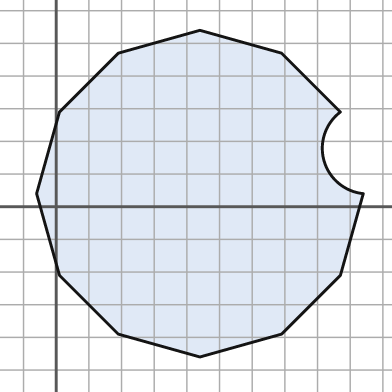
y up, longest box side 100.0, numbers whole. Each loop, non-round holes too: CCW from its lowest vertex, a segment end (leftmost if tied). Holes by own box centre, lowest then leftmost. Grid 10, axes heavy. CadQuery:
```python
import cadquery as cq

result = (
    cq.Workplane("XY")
    .moveTo(44.0, -46.0)
    .lineTo(69.0, -39.0)
    .lineTo(87.0, -21.0)
    .lineTo(94.0, 4.0)
    .threePointArc((82.0, 14.0), (87.0, 29.0))
    .lineTo(69.0, 47.0)
    .lineTo(44.0, 54.0)
    .lineTo(19.0, 47.0)
    .lineTo(1.0, 29.0)
    .lineTo(-6.0, 4.0)
    .lineTo(1.0, -21.0)
    .lineTo(19.0, -39.0)
    .close()
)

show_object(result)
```